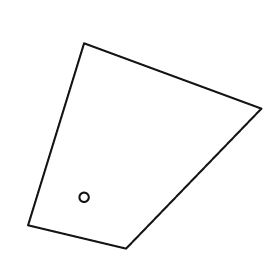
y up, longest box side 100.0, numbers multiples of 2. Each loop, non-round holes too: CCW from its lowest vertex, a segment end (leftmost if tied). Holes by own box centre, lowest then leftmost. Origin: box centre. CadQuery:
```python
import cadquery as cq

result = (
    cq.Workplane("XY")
    .moveTo(-8.0, -44.0)
    .lineTo(50.0, 16.0)
    .lineTo(-26.0, 44.0)
    .lineTo(-50.0, -34.0)
    .close()
    .moveTo(-26.0, -22.0)
    .circle(2.0)
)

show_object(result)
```